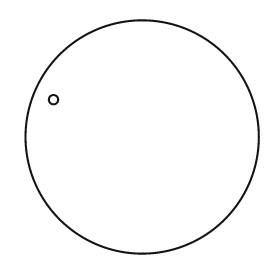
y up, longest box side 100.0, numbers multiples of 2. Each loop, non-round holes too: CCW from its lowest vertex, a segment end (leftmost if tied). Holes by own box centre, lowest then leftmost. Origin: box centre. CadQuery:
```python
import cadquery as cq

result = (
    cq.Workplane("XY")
    .moveTo(0.0, 0.0)
    .circle(50.0)
    .moveTo(-38.0, 16.0)
    .circle(2.0)
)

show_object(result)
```